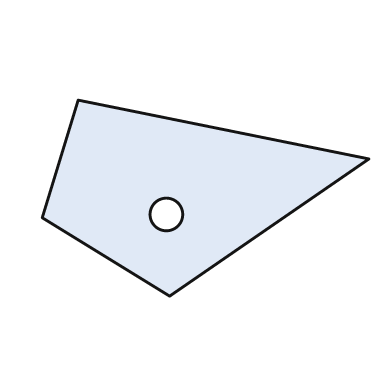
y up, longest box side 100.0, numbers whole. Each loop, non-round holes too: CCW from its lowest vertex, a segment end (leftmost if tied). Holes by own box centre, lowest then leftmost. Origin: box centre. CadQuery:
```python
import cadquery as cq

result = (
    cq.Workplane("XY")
    .moveTo(-11.0, -30.0)
    .lineTo(50.0, 12.0)
    .lineTo(-39.0, 30.0)
    .lineTo(-50.0, -6.0)
    .close()
    .moveTo(-12.0, -5.0)
    .circle(5.0)
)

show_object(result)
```